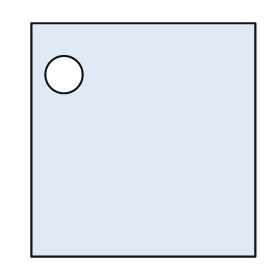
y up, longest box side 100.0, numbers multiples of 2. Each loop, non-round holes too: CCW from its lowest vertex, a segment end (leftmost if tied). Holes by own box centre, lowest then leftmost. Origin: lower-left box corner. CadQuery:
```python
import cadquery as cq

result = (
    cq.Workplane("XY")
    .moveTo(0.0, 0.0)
    .lineTo(96.0, 0.0)
    .lineTo(96.0, 100.0)
    .lineTo(0.0, 100.0)
    .close()
    .moveTo(14.0, 78.0)
    .circle(8.0)
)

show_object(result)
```